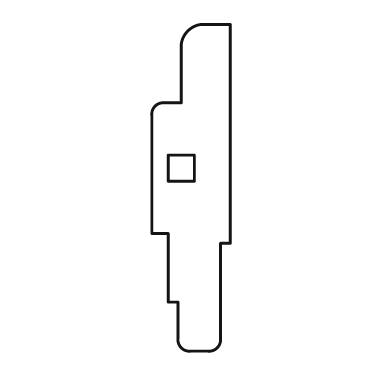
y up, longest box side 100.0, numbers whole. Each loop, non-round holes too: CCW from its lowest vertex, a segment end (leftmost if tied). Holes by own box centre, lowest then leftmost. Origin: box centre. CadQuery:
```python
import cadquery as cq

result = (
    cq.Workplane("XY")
    .moveTo(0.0, -50.0)
    .lineTo(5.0, -50.0)
    .threePointArc((8.0, -49.0), (9.0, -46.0))
    .lineTo(9.0, -17.0)
    .lineTo(12.0, -17.0)
    .lineTo(12.0, 50.0)
    .lineTo(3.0, 50.0)
    .threePointArc((-1.0, 48.0), (-3.0, 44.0))
    .lineTo(-3.0, 26.0)
    .lineTo(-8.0, 26.0)
    .threePointArc((-11.0, 25.0), (-12.0, 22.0))
    .lineTo(-12.0, -14.0)
    .lineTo(-7.0, -14.0)
    .lineTo(-7.0, -35.0)
    .lineTo(-4.0, -35.0)
    .lineTo(-4.0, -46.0)
    .threePointArc((-3.0, -49.0), (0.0, -50.0))
    .close()
    .moveTo(-7.0, 2.0)
    .lineTo(1.0, 2.0)
    .lineTo(1.0, 10.0)
    .lineTo(-7.0, 10.0)
    .close()
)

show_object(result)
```